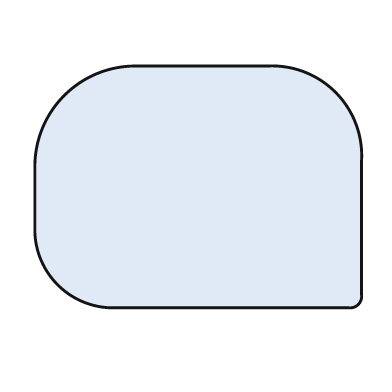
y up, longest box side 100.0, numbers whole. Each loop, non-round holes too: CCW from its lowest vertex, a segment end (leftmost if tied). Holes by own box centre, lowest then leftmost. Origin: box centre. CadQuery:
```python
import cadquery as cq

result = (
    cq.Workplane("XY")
    .moveTo(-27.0, -37.0)
    .lineTo(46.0, -37.0)
    .threePointArc((49.0, -36.0), (50.0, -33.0))
    .lineTo(50.0, 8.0)
    .threePointArc((42.0, 29.0), (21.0, 37.0))
    .lineTo(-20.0, 37.0)
    .threePointArc((-41.0, 28.0), (-50.0, 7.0))
    .lineTo(-50.0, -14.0)
    .threePointArc((-43.0, -30.0), (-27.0, -37.0))
    .close()
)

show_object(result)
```